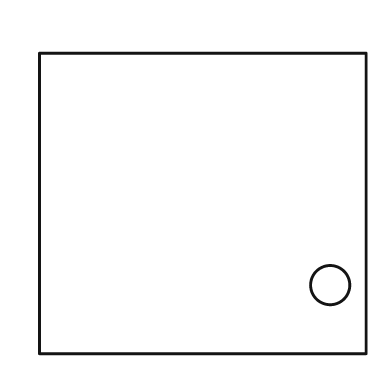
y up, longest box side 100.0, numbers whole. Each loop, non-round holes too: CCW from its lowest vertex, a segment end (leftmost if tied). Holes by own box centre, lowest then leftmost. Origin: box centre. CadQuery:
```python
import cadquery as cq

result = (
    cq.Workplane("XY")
    .moveTo(-50.0, -46.0)
    .lineTo(50.0, -46.0)
    .lineTo(50.0, 46.0)
    .lineTo(-50.0, 46.0)
    .close()
    .moveTo(39.0, -25.0)
    .circle(6.0)
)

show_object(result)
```